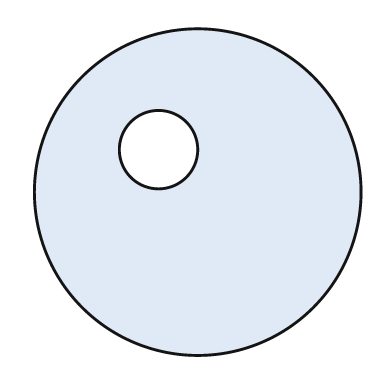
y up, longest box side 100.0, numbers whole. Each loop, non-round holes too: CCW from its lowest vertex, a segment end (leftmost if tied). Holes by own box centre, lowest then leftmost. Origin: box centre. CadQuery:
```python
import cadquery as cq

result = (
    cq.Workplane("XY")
    .moveTo(0.0, 0.0)
    .circle(50.0)
    .moveTo(-12.0, 13.0)
    .circle(12.0)
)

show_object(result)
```